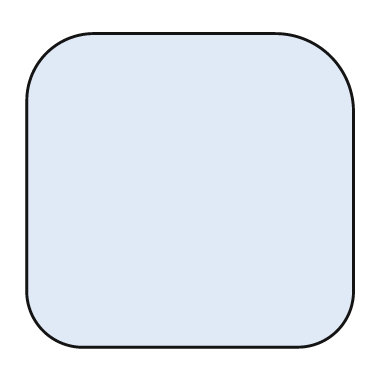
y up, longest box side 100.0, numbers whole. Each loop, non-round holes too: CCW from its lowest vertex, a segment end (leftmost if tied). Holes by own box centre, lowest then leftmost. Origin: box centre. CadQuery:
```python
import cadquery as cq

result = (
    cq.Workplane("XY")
    .moveTo(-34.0, -48.0)
    .lineTo(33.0, -48.0)
    .threePointArc((45.0, -43.0), (50.0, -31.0))
    .lineTo(50.0, 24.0)
    .threePointArc((43.0, 41.0), (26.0, 48.0))
    .lineTo(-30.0, 48.0)
    .threePointArc((-44.0, 42.0), (-50.0, 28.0))
    .lineTo(-50.0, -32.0)
    .threePointArc((-45.0, -43.0), (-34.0, -48.0))
    .close()
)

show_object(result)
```